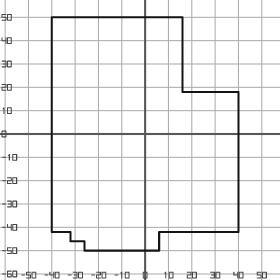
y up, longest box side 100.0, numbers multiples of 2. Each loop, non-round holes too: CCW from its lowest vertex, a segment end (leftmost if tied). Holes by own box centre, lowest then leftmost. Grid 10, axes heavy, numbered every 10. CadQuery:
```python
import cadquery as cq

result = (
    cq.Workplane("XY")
    .moveTo(-26.0, -50.0)
    .lineTo(6.0, -50.0)
    .lineTo(6.0, -42.0)
    .lineTo(40.0, -42.0)
    .lineTo(40.0, 18.0)
    .lineTo(16.0, 18.0)
    .lineTo(16.0, 50.0)
    .lineTo(-40.0, 50.0)
    .lineTo(-40.0, -42.0)
    .lineTo(-32.0, -42.0)
    .lineTo(-32.0, -46.0)
    .lineTo(-26.0, -46.0)
    .close()
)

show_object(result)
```